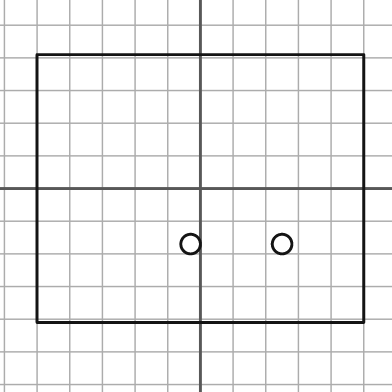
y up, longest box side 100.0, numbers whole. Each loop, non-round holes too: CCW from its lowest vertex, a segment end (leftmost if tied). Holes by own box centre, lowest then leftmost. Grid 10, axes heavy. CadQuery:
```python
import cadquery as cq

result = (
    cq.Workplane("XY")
    .moveTo(-50.0, -41.0)
    .lineTo(50.0, -41.0)
    .lineTo(50.0, 41.0)
    .lineTo(-50.0, 41.0)
    .close()
    .moveTo(-3.0, -17.0)
    .circle(3.0)
    .moveTo(25.0, -17.0)
    .circle(3.0)
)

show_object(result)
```